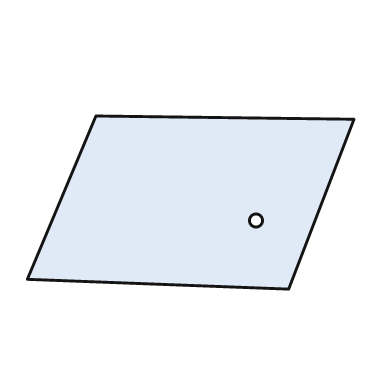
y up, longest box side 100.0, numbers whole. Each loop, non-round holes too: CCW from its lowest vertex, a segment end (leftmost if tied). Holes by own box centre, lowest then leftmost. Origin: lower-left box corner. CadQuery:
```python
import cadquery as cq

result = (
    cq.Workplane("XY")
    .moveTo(80.0, 0.0)
    .lineTo(100.0, 52.0)
    .lineTo(21.0, 53.0)
    .lineTo(0.0, 3.0)
    .close()
    .moveTo(70.0, 21.0)
    .circle(2.0)
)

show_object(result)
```